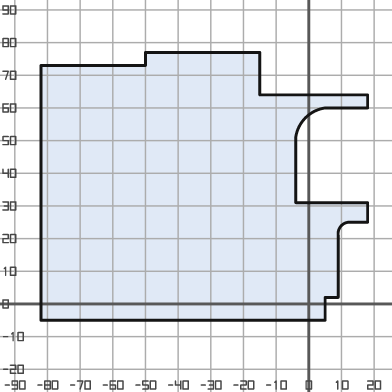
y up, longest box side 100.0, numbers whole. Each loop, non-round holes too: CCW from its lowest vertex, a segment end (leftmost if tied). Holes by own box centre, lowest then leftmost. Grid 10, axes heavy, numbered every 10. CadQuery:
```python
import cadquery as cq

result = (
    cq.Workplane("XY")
    .moveTo(-82.0, -5.0)
    .lineTo(5.0, -5.0)
    .lineTo(5.0, 2.0)
    .lineTo(9.0, 2.0)
    .lineTo(9.0, 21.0)
    .threePointArc((10.0, 24.0), (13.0, 25.0))
    .lineTo(18.0, 25.0)
    .lineTo(18.0, 31.0)
    .lineTo(-4.0, 31.0)
    .lineTo(-4.0, 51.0)
    .threePointArc((-1.0, 57.0), (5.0, 60.0))
    .lineTo(18.0, 60.0)
    .lineTo(18.0, 64.0)
    .lineTo(-15.0, 64.0)
    .lineTo(-15.0, 77.0)
    .lineTo(-50.0, 77.0)
    .lineTo(-50.0, 73.0)
    .lineTo(-82.0, 73.0)
    .close()
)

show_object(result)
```